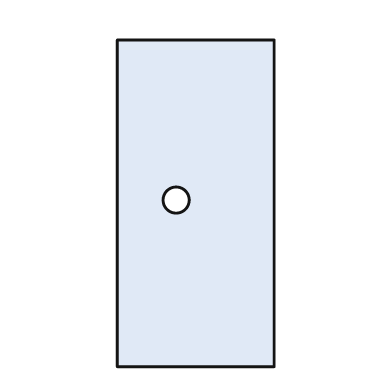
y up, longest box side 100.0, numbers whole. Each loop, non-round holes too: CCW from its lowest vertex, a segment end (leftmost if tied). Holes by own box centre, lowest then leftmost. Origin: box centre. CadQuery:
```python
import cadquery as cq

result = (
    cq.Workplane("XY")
    .moveTo(-24.0, -50.0)
    .lineTo(24.0, -50.0)
    .lineTo(24.0, 50.0)
    .lineTo(-24.0, 50.0)
    .close()
    .moveTo(-6.0, 1.0)
    .circle(4.0)
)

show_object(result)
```